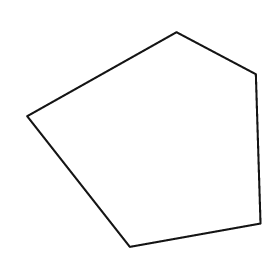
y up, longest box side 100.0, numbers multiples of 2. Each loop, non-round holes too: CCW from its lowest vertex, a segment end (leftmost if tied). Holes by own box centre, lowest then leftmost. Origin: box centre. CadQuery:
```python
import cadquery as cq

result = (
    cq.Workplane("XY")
    .moveTo(-6.0, -46.0)
    .lineTo(50.0, -36.0)
    .lineTo(48.0, 28.0)
    .lineTo(14.0, 46.0)
    .lineTo(-50.0, 10.0)
    .close()
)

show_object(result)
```